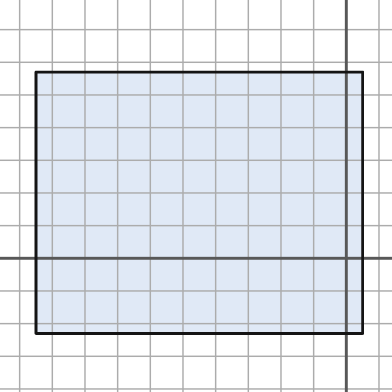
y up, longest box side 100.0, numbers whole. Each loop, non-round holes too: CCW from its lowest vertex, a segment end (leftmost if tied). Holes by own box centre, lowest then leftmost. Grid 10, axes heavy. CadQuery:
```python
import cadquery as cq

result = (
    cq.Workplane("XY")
    .moveTo(-95.0, -23.0)
    .lineTo(5.0, -23.0)
    .lineTo(5.0, 57.0)
    .lineTo(-95.0, 57.0)
    .close()
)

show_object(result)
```